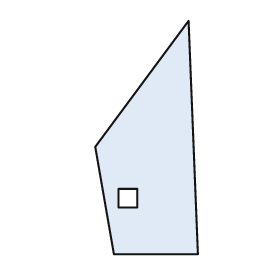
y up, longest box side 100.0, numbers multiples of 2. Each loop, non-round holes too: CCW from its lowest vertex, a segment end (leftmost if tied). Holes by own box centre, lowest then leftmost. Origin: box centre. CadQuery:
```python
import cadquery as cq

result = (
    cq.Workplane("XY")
    .moveTo(-14.0, -50.0)
    .lineTo(22.0, -50.0)
    .lineTo(18.0, 50.0)
    .lineTo(-22.0, -4.0)
    .close()
    .moveTo(-12.0, -30.0)
    .lineTo(-4.0, -30.0)
    .lineTo(-4.0, -22.0)
    .lineTo(-12.0, -22.0)
    .close()
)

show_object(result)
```